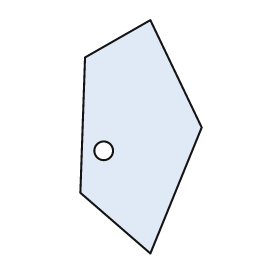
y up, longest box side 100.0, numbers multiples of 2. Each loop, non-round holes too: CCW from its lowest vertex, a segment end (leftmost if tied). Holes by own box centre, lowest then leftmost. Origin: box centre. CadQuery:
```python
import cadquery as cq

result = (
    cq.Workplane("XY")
    .moveTo(4.0, -50.0)
    .lineTo(26.0, 4.0)
    .lineTo(4.0, 50.0)
    .lineTo(-24.0, 34.0)
    .lineTo(-26.0, -24.0)
    .close()
    .moveTo(-16.0, -6.0)
    .circle(4.0)
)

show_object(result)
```